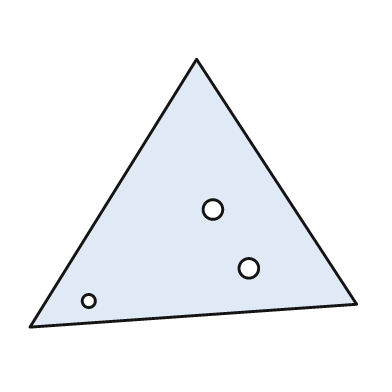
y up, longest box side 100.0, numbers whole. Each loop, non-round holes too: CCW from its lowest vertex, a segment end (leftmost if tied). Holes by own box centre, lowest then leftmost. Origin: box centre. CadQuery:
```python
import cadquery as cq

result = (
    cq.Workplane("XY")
    .moveTo(-50.0, -41.0)
    .lineTo(50.0, -34.0)
    .lineTo(1.0, 41.0)
    .close()
    .moveTo(-32.0, -33.0)
    .circle(2.0)
    .moveTo(17.0, -23.0)
    .circle(3.0)
    .moveTo(6.0, -5.0)
    .circle(3.0)
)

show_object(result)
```